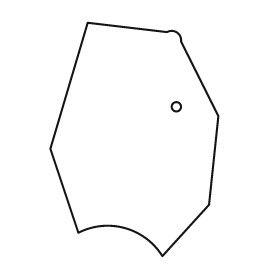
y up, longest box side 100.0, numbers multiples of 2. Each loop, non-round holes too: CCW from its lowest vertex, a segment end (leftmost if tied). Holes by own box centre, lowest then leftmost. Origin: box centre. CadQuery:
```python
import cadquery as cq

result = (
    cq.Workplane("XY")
    .moveTo(12.0, -50.0)
    .lineTo(32.0, -28.0)
    .lineTo(36.0, 10.0)
    .lineTo(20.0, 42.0)
    .threePointArc((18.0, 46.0), (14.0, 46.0))
    .lineTo(-20.0, 50.0)
    .lineTo(-36.0, -4.0)
    .lineTo(-24.0, -40.0)
    .threePointArc((-4.0, -38.0), (12.0, -50.0))
    .close()
    .moveTo(18.0, 14.0)
    .circle(2.0)
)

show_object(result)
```